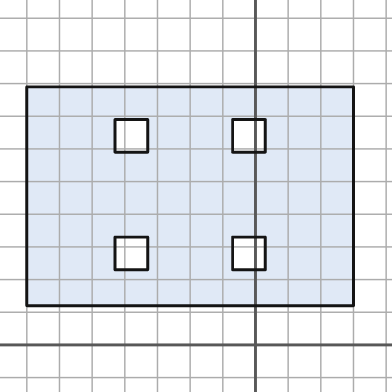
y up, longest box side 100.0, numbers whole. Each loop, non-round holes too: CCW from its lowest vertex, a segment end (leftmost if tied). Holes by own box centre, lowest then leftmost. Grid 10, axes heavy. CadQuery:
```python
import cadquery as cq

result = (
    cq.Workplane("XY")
    .moveTo(-70.0, 12.0)
    .lineTo(30.0, 12.0)
    .lineTo(30.0, 79.0)
    .lineTo(-70.0, 79.0)
    .close()
    .moveTo(-43.0, 23.0)
    .lineTo(-33.0, 23.0)
    .lineTo(-33.0, 33.0)
    .lineTo(-43.0, 33.0)
    .close()
    .moveTo(-7.0, 23.0)
    .lineTo(3.0, 23.0)
    .lineTo(3.0, 33.0)
    .lineTo(-7.0, 33.0)
    .close()
    .moveTo(-43.0, 59.0)
    .lineTo(-33.0, 59.0)
    .lineTo(-33.0, 69.0)
    .lineTo(-43.0, 69.0)
    .close()
    .moveTo(-7.0, 59.0)
    .lineTo(3.0, 59.0)
    .lineTo(3.0, 69.0)
    .lineTo(-7.0, 69.0)
    .close()
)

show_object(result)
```